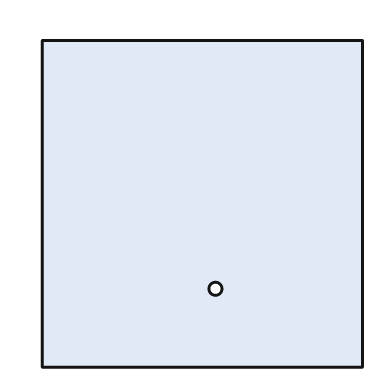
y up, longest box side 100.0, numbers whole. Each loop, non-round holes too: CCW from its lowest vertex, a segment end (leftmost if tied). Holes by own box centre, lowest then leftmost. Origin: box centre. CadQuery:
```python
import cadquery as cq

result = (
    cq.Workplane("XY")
    .moveTo(-49.0, -50.0)
    .lineTo(49.0, -50.0)
    .lineTo(49.0, 50.0)
    .lineTo(-49.0, 50.0)
    .close()
    .moveTo(4.0, -26.0)
    .circle(2.0)
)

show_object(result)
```